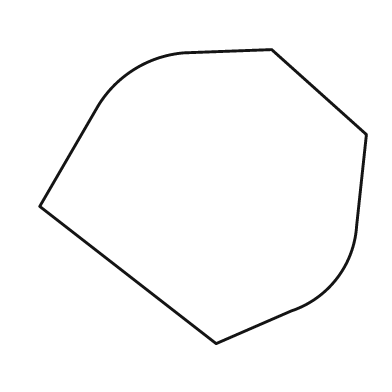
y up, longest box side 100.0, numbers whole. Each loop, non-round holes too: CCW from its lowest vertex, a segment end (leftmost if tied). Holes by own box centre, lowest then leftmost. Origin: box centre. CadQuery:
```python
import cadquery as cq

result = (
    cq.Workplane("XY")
    .moveTo(4.0, -45.0)
    .lineTo(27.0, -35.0)
    .threePointArc((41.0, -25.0), (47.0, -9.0))
    .lineTo(50.0, 19.0)
    .lineTo(21.0, 45.0)
    .lineTo(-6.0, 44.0)
    .threePointArc((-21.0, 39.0), (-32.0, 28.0))
    .lineTo(-50.0, -3.0)
    .close()
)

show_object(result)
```